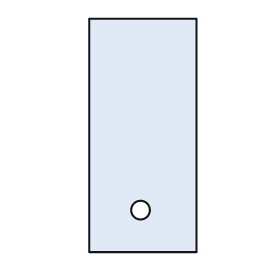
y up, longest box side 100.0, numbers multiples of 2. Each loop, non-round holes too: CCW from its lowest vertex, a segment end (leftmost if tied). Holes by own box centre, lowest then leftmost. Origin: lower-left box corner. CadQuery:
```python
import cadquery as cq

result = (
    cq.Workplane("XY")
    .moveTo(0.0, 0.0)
    .lineTo(46.0, 0.0)
    .lineTo(46.0, 100.0)
    .lineTo(0.0, 100.0)
    .close()
    .moveTo(22.0, 18.0)
    .circle(4.0)
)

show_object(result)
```